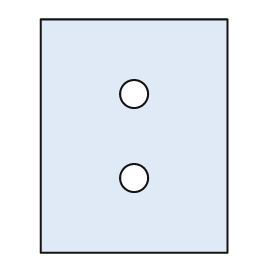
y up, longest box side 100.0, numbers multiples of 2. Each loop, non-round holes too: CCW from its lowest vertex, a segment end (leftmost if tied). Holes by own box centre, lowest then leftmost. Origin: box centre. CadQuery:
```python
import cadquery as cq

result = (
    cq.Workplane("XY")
    .moveTo(-40.0, -50.0)
    .lineTo(40.0, -50.0)
    .lineTo(40.0, 50.0)
    .lineTo(-40.0, 50.0)
    .close()
    .moveTo(0.0, -18.0)
    .circle(6.0)
    .moveTo(0.0, 18.0)
    .circle(6.0)
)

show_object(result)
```